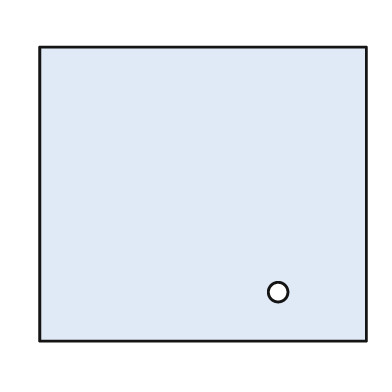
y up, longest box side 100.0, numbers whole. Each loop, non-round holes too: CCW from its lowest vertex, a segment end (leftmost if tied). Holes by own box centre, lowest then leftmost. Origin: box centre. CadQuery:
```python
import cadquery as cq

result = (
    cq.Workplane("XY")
    .moveTo(-50.0, -45.0)
    .lineTo(50.0, -45.0)
    .lineTo(50.0, 45.0)
    .lineTo(-50.0, 45.0)
    .close()
    .moveTo(23.0, -30.0)
    .circle(3.0)
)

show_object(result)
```